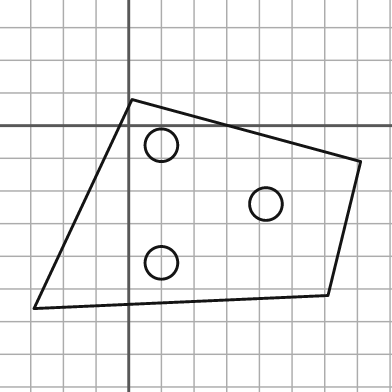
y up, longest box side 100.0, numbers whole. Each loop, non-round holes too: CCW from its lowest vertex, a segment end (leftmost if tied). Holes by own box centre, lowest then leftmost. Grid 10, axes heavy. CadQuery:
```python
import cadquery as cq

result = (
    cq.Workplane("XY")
    .moveTo(-29.0, -56.0)
    .lineTo(61.0, -52.0)
    .lineTo(71.0, -11.0)
    .lineTo(1.0, 8.0)
    .close()
    .moveTo(10.0, -42.0)
    .circle(5.0)
    .moveTo(42.0, -24.0)
    .circle(5.0)
    .moveTo(10.0, -6.0)
    .circle(5.0)
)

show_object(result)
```